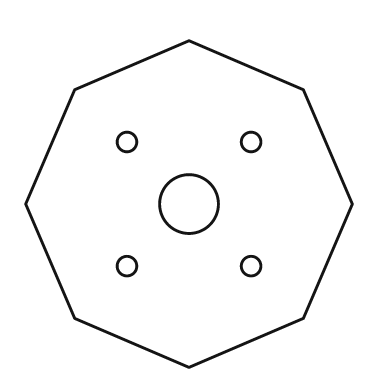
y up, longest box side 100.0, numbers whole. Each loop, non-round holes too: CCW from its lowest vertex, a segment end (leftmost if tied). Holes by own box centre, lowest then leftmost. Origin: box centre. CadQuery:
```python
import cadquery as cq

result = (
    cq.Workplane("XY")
    .moveTo(0.0, -50.0)
    .lineTo(35.0, -35.0)
    .lineTo(50.0, 0.0)
    .lineTo(35.0, 35.0)
    .lineTo(0.0, 50.0)
    .lineTo(-35.0, 35.0)
    .lineTo(-50.0, 0.0)
    .lineTo(-35.0, -35.0)
    .close()
    .moveTo(-19.0, -19.0)
    .circle(3.0)
    .moveTo(19.0, -19.0)
    .circle(3.0)
    .moveTo(0.0, 0.0)
    .circle(9.0)
    .moveTo(-19.0, 19.0)
    .circle(3.0)
    .moveTo(19.0, 19.0)
    .circle(3.0)
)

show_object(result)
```